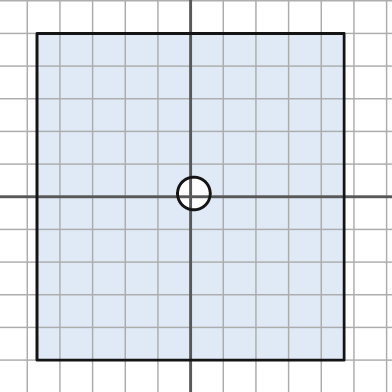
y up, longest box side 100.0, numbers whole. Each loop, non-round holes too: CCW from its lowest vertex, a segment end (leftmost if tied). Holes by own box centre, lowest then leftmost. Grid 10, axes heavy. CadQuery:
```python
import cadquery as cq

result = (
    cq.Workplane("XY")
    .moveTo(-47.0, -50.0)
    .lineTo(47.0, -50.0)
    .lineTo(47.0, 50.0)
    .lineTo(-47.0, 50.0)
    .close()
    .moveTo(1.0, 1.0)
    .circle(5.0)
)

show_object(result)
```